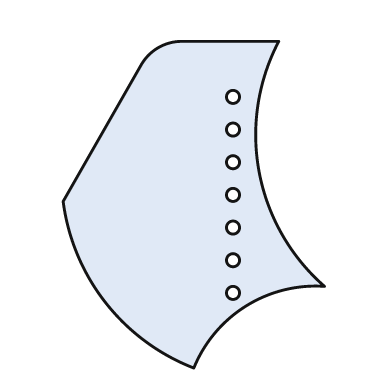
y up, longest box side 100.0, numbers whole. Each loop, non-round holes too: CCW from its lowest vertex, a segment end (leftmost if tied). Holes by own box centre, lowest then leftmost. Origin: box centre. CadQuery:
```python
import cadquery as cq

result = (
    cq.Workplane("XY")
    .moveTo(0.0, -50.0)
    .threePointArc((16.0, -31.0), (40.0, -25.0))
    .threePointArc((20.0, 10.0), (26.0, 50.0))
    .lineTo(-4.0, 50.0)
    .threePointArc((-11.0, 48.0), (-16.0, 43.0))
    .lineTo(-40.0, 1.0)
    .threePointArc((-27.0, -30.0), (0.0, -50.0))
    .close()
    .moveTo(12.0, -27.0)
    .circle(2.0)
    .moveTo(12.0, -17.0)
    .circle(2.0)
    .moveTo(12.0, -7.0)
    .circle(2.0)
    .moveTo(12.0, 3.0)
    .circle(2.0)
    .moveTo(12.0, 13.0)
    .circle(2.0)
    .moveTo(12.0, 23.0)
    .circle(2.0)
    .moveTo(12.0, 33.0)
    .circle(2.0)
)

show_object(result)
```